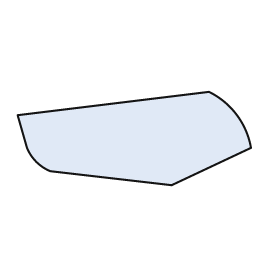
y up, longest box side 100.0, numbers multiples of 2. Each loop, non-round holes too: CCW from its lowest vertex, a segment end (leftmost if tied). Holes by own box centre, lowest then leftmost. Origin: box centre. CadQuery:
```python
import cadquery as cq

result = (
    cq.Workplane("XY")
    .moveTo(16.0, -20.0)
    .lineTo(50.0, -4.0)
    .threePointArc((44.0, 10.0), (32.0, 20.0))
    .lineTo(-50.0, 10.0)
    .lineTo(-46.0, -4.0)
    .threePointArc((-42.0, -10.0), (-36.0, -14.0))
    .close()
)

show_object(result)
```